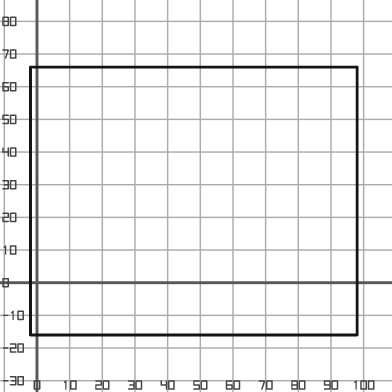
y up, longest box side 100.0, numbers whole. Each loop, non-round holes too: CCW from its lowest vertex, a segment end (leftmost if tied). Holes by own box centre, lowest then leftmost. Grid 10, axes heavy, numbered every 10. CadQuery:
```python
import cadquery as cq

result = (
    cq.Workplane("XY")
    .moveTo(-2.0, -16.0)
    .lineTo(98.0, -16.0)
    .lineTo(98.0, 66.0)
    .lineTo(-2.0, 66.0)
    .close()
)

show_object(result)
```